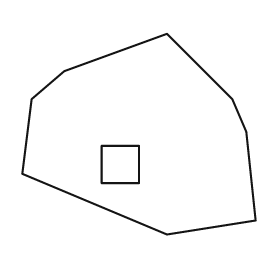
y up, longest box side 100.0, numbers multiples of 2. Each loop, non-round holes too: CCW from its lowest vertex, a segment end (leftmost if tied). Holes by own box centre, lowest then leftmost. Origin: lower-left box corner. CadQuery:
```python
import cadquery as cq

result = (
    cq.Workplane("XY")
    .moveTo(62.0, 0.0)
    .lineTo(100.0, 6.0)
    .lineTo(96.0, 44.0)
    .lineTo(90.0, 58.0)
    .lineTo(62.0, 86.0)
    .lineTo(18.0, 70.0)
    .lineTo(4.0, 58.0)
    .lineTo(0.0, 26.0)
    .close()
    .moveTo(34.0, 22.0)
    .lineTo(50.0, 22.0)
    .lineTo(50.0, 38.0)
    .lineTo(34.0, 38.0)
    .close()
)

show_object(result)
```